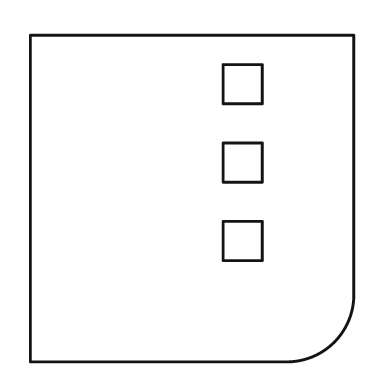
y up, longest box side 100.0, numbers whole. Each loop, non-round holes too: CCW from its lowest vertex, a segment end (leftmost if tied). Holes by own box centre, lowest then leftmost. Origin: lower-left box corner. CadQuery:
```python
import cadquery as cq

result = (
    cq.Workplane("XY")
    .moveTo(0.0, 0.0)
    .lineTo(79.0, 0.0)
    .threePointArc((93.0, 6.0), (99.0, 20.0))
    .lineTo(99.0, 100.0)
    .lineTo(0.0, 100.0)
    .close()
    .moveTo(59.0, 31.0)
    .lineTo(71.0, 31.0)
    .lineTo(71.0, 43.0)
    .lineTo(59.0, 43.0)
    .close()
    .moveTo(59.0, 55.0)
    .lineTo(71.0, 55.0)
    .lineTo(71.0, 67.0)
    .lineTo(59.0, 67.0)
    .close()
    .moveTo(59.0, 79.0)
    .lineTo(71.0, 79.0)
    .lineTo(71.0, 91.0)
    .lineTo(59.0, 91.0)
    .close()
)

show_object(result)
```